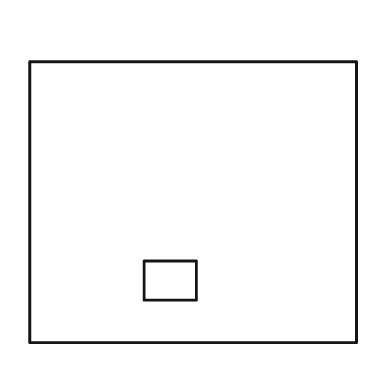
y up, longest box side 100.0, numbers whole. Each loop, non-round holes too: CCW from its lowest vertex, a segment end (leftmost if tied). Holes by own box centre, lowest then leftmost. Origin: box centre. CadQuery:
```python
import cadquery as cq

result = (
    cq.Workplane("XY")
    .moveTo(-50.0, -43.0)
    .lineTo(50.0, -43.0)
    .lineTo(50.0, 43.0)
    .lineTo(-50.0, 43.0)
    .close()
    .moveTo(-15.0, -30.0)
    .lineTo(1.0, -30.0)
    .lineTo(1.0, -18.0)
    .lineTo(-15.0, -18.0)
    .close()
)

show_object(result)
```